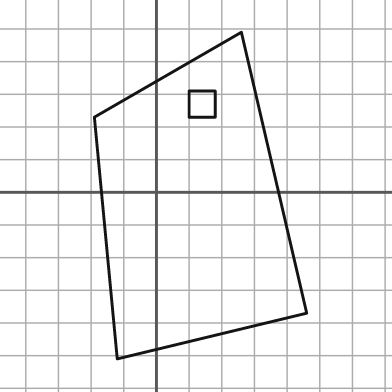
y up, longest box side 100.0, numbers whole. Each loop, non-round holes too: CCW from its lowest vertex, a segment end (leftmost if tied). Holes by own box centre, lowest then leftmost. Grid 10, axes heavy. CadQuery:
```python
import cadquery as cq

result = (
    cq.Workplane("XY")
    .moveTo(-12.0, -51.0)
    .lineTo(46.0, -37.0)
    .lineTo(26.0, 49.0)
    .lineTo(-19.0, 23.0)
    .close()
    .moveTo(10.0, 23.0)
    .lineTo(18.0, 23.0)
    .lineTo(18.0, 31.0)
    .lineTo(10.0, 31.0)
    .close()
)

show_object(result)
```